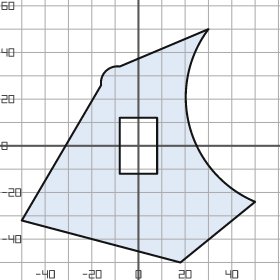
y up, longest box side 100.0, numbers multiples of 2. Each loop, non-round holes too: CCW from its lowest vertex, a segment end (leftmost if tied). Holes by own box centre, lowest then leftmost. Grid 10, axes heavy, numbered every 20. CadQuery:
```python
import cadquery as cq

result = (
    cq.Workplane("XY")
    .moveTo(18.0, -50.0)
    .lineTo(50.0, -24.0)
    .threePointArc((22.0, 8.0), (30.0, 50.0))
    .lineTo(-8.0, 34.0)
    .threePointArc((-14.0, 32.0), (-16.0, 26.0))
    .lineTo(-50.0, -32.0)
    .close()
    .moveTo(-8.0, -12.0)
    .lineTo(8.0, -12.0)
    .lineTo(8.0, 12.0)
    .lineTo(-8.0, 12.0)
    .close()
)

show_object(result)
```